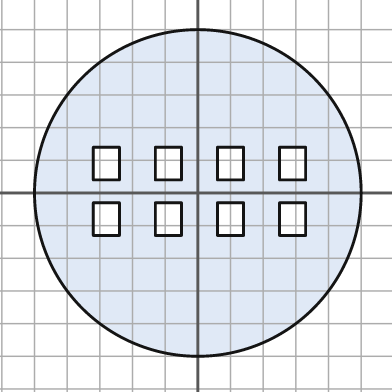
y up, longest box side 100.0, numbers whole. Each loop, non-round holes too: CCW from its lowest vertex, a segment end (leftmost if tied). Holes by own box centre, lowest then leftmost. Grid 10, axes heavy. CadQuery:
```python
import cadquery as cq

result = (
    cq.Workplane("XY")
    .moveTo(0.0, 0.0)
    .circle(50.0)
    .moveTo(-32.0, -13.0)
    .lineTo(-24.0, -13.0)
    .lineTo(-24.0, -3.0)
    .lineTo(-32.0, -3.0)
    .close()
    .moveTo(-13.0, -13.0)
    .lineTo(-5.0, -13.0)
    .lineTo(-5.0, -3.0)
    .lineTo(-13.0, -3.0)
    .close()
    .moveTo(6.0, -13.0)
    .lineTo(14.0, -13.0)
    .lineTo(14.0, -3.0)
    .lineTo(6.0, -3.0)
    .close()
    .moveTo(25.0, -13.0)
    .lineTo(33.0, -13.0)
    .lineTo(33.0, -3.0)
    .lineTo(25.0, -3.0)
    .close()
    .moveTo(-32.0, 4.0)
    .lineTo(-24.0, 4.0)
    .lineTo(-24.0, 14.0)
    .lineTo(-32.0, 14.0)
    .close()
    .moveTo(-13.0, 4.0)
    .lineTo(-5.0, 4.0)
    .lineTo(-5.0, 14.0)
    .lineTo(-13.0, 14.0)
    .close()
    .moveTo(6.0, 4.0)
    .lineTo(14.0, 4.0)
    .lineTo(14.0, 14.0)
    .lineTo(6.0, 14.0)
    .close()
    .moveTo(25.0, 4.0)
    .lineTo(33.0, 4.0)
    .lineTo(33.0, 14.0)
    .lineTo(25.0, 14.0)
    .close()
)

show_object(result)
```